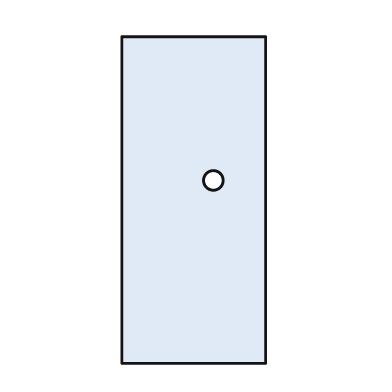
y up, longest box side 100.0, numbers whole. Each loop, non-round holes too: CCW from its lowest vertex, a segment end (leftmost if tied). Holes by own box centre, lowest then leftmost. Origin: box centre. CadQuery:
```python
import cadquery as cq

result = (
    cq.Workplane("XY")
    .moveTo(-22.0, -50.0)
    .lineTo(22.0, -50.0)
    .lineTo(22.0, 50.0)
    .lineTo(-22.0, 50.0)
    .close()
    .moveTo(6.0, 6.0)
    .circle(3.0)
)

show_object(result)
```